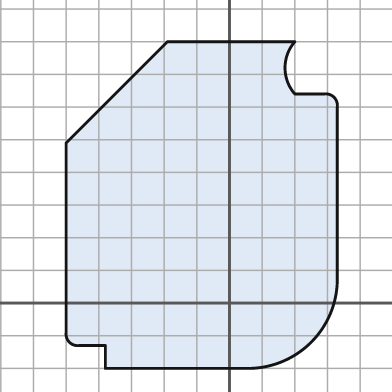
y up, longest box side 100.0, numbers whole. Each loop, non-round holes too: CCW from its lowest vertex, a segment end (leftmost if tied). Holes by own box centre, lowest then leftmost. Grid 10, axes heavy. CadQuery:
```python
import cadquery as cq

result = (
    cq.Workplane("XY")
    .moveTo(-38.0, -20.0)
    .lineTo(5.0, -20.0)
    .threePointArc((25.0, -12.0), (33.0, 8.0))
    .lineTo(33.0, 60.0)
    .threePointArc((32.0, 63.0), (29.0, 64.0))
    .lineTo(20.0, 64.0)
    .threePointArc((17.0, 72.0), (20.0, 80.0))
    .lineTo(-19.0, 80.0)
    .lineTo(-50.0, 49.0)
    .lineTo(-50.0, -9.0)
    .threePointArc((-49.0, -12.0), (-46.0, -13.0))
    .lineTo(-38.0, -13.0)
    .close()
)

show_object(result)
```